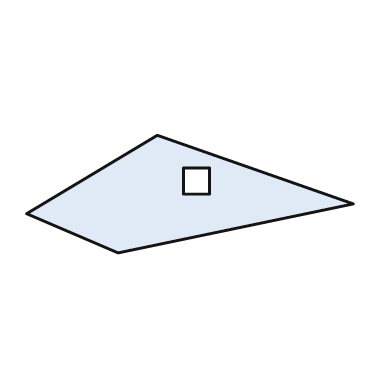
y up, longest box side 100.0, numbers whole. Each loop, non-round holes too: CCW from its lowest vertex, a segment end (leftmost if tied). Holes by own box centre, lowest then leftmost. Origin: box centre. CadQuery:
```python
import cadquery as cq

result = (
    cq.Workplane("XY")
    .moveTo(-22.0, -18.0)
    .lineTo(50.0, -3.0)
    .lineTo(-10.0, 18.0)
    .lineTo(-50.0, -6.0)
    .close()
    .moveTo(-2.0, 0.0)
    .lineTo(6.0, 0.0)
    .lineTo(6.0, 8.0)
    .lineTo(-2.0, 8.0)
    .close()
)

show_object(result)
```